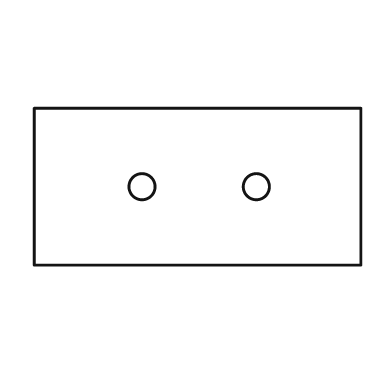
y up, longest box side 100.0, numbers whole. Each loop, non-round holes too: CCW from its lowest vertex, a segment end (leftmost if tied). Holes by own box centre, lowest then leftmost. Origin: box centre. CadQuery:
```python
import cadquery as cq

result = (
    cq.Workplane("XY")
    .moveTo(-50.0, -24.0)
    .lineTo(50.0, -24.0)
    .lineTo(50.0, 24.0)
    .lineTo(-50.0, 24.0)
    .close()
    .moveTo(-17.0, 0.0)
    .circle(4.0)
    .moveTo(18.0, 0.0)
    .circle(4.0)
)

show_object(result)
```